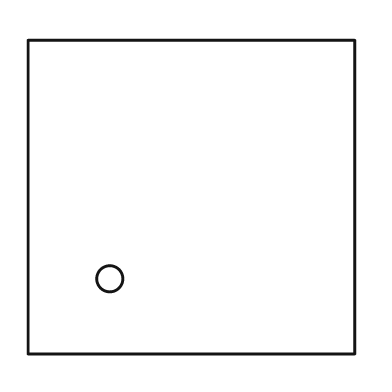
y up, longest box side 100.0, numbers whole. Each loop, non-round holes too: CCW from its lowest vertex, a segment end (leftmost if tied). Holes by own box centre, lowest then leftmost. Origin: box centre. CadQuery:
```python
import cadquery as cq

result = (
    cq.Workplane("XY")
    .moveTo(-50.0, -48.0)
    .lineTo(50.0, -48.0)
    .lineTo(50.0, 48.0)
    .lineTo(-50.0, 48.0)
    .close()
    .moveTo(-25.0, -25.0)
    .circle(4.0)
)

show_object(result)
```